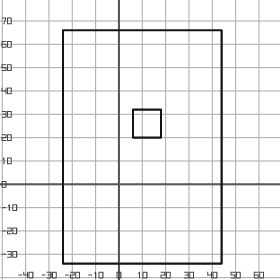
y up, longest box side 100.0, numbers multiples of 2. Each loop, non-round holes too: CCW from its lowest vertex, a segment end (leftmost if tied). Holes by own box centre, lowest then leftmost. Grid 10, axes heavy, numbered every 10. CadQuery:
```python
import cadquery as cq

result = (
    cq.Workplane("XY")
    .moveTo(-24.0, -34.0)
    .lineTo(44.0, -34.0)
    .lineTo(44.0, 66.0)
    .lineTo(-24.0, 66.0)
    .close()
    .moveTo(6.0, 20.0)
    .lineTo(18.0, 20.0)
    .lineTo(18.0, 32.0)
    .lineTo(6.0, 32.0)
    .close()
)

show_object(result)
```